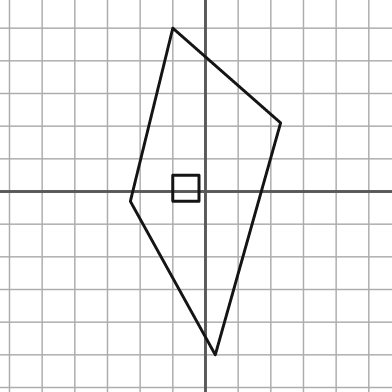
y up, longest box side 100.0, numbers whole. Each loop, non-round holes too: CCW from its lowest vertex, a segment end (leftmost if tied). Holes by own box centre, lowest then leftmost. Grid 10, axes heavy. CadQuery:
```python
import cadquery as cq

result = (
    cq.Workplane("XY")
    .moveTo(3.0, -50.0)
    .lineTo(23.0, 21.0)
    .lineTo(-10.0, 50.0)
    .lineTo(-23.0, -3.0)
    .close()
    .moveTo(-10.0, -3.0)
    .lineTo(-2.0, -3.0)
    .lineTo(-2.0, 5.0)
    .lineTo(-10.0, 5.0)
    .close()
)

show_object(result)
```